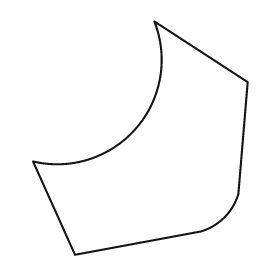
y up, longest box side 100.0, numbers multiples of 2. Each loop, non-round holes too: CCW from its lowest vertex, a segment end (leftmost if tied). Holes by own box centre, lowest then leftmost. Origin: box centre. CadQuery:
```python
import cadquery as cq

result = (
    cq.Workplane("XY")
    .moveTo(-28.0, -50.0)
    .lineTo(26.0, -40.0)
    .threePointArc((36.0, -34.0), (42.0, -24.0))
    .lineTo(46.0, 24.0)
    .lineTo(6.0, 50.0)
    .threePointArc((-2.0, 4.0), (-46.0, -10.0))
    .close()
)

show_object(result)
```